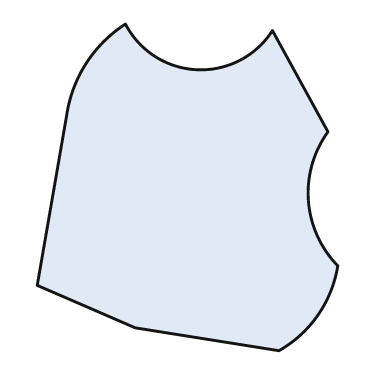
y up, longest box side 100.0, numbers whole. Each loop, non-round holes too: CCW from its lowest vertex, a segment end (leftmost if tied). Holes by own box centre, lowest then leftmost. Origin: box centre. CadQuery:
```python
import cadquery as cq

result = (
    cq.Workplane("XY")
    .moveTo(28.0, -50.0)
    .threePointArc((40.0, -39.0), (46.0, -24.0))
    .threePointArc((37.0, -4.0), (43.0, 17.0))
    .lineTo(26.0, 48.0)
    .threePointArc((3.0, 36.0), (-19.0, 50.0))
    .threePointArc((-31.0, 38.0), (-37.0, 22.0))
    .lineTo(-46.0, -30.0)
    .lineTo(-16.0, -43.0)
    .close()
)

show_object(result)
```